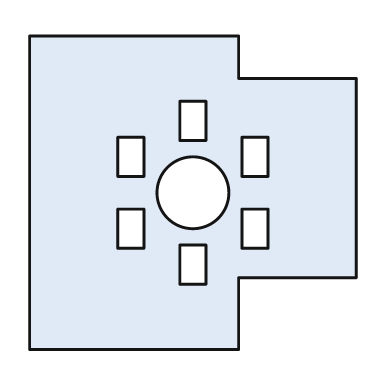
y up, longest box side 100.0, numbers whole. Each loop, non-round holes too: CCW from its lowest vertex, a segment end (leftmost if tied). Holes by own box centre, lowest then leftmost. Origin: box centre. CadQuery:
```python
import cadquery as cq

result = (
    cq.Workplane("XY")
    .moveTo(-50.0, -48.0)
    .lineTo(14.0, -48.0)
    .lineTo(14.0, -26.0)
    .lineTo(50.0, -26.0)
    .lineTo(50.0, 35.0)
    .lineTo(14.0, 35.0)
    .lineTo(14.0, 48.0)
    .lineTo(-50.0, 48.0)
    .close()
    .moveTo(-4.0, -28.0)
    .lineTo(4.0, -28.0)
    .lineTo(4.0, -16.0)
    .lineTo(-4.0, -16.0)
    .close()
    .moveTo(-23.0, -17.0)
    .lineTo(-15.0, -17.0)
    .lineTo(-15.0, -5.0)
    .lineTo(-23.0, -5.0)
    .close()
    .moveTo(15.0, -17.0)
    .lineTo(23.0, -17.0)
    .lineTo(23.0, -5.0)
    .lineTo(15.0, -5.0)
    .close()
    .moveTo(0.0, 0.0)
    .circle(11.0)
    .moveTo(-23.0, 5.0)
    .lineTo(-15.0, 5.0)
    .lineTo(-15.0, 17.0)
    .lineTo(-23.0, 17.0)
    .close()
    .moveTo(15.0, 5.0)
    .lineTo(23.0, 5.0)
    .lineTo(23.0, 17.0)
    .lineTo(15.0, 17.0)
    .close()
    .moveTo(-4.0, 16.0)
    .lineTo(4.0, 16.0)
    .lineTo(4.0, 28.0)
    .lineTo(-4.0, 28.0)
    .close()
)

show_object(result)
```